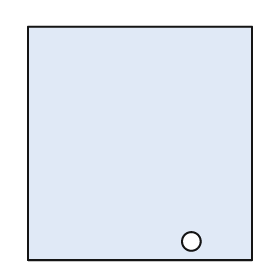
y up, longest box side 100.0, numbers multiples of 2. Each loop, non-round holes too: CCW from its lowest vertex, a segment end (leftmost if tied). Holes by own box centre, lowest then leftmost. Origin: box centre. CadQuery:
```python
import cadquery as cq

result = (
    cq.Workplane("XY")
    .moveTo(-48.0, -50.0)
    .lineTo(48.0, -50.0)
    .lineTo(48.0, 50.0)
    .lineTo(-48.0, 50.0)
    .close()
    .moveTo(22.0, -42.0)
    .circle(4.0)
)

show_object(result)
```